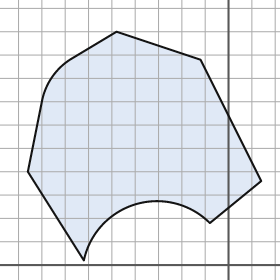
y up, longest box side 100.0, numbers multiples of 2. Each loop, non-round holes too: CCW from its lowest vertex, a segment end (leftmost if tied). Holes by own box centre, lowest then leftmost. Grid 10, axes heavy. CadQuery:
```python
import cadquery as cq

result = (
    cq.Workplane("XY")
    .moveTo(-62.0, 2.0)
    .threePointArc((-40.0, 26.0), (-8.0, 18.0))
    .lineTo(14.0, 36.0)
    .lineTo(-12.0, 88.0)
    .lineTo(-48.0, 100.0)
    .lineTo(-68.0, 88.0)
    .threePointArc((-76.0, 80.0), (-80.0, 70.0))
    .lineTo(-86.0, 40.0)
    .close()
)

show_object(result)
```